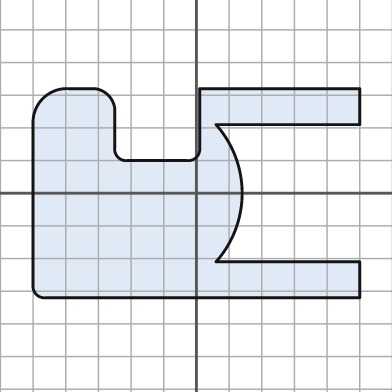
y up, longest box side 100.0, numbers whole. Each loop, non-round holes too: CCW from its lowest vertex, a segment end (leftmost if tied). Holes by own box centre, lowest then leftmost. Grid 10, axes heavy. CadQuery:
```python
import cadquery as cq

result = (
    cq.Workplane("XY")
    .moveTo(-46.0, -32.0)
    .lineTo(50.0, -32.0)
    .lineTo(50.0, -21.0)
    .lineTo(6.0, -21.0)
    .threePointArc((14.0, 0.0), (6.0, 21.0))
    .lineTo(50.0, 21.0)
    .lineTo(50.0, 32.0)
    .lineTo(1.0, 32.0)
    .lineTo(1.0, 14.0)
    .threePointArc((0.0, 11.0), (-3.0, 10.0))
    .lineTo(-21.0, 10.0)
    .threePointArc((-24.0, 11.0), (-25.0, 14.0))
    .lineTo(-25.0, 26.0)
    .threePointArc((-27.0, 30.0), (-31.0, 32.0))
    .lineTo(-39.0, 32.0)
    .threePointArc((-47.0, 29.0), (-50.0, 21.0))
    .lineTo(-50.0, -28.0)
    .threePointArc((-49.0, -31.0), (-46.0, -32.0))
    .close()
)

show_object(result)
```